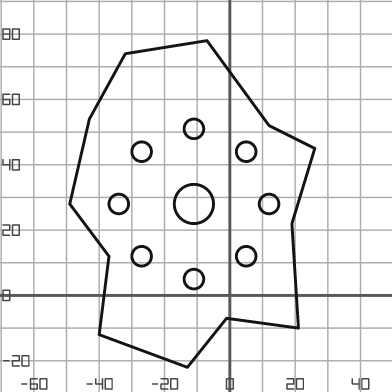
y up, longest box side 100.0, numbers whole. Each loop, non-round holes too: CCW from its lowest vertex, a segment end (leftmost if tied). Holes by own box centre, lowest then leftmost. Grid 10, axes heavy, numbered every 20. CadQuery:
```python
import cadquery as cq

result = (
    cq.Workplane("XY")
    .moveTo(-13.0, -22.0)
    .lineTo(-1.0, -7.0)
    .lineTo(21.0, -10.0)
    .lineTo(19.0, 22.0)
    .lineTo(26.0, 45.0)
    .lineTo(12.0, 52.0)
    .lineTo(-7.0, 78.0)
    .lineTo(-32.0, 74.0)
    .lineTo(-43.0, 54.0)
    .lineTo(-49.0, 28.0)
    .lineTo(-37.0, 12.0)
    .lineTo(-40.0, -12.0)
    .close()
    .moveTo(-11.0, 5.0)
    .circle(3.0)
    .moveTo(-27.0, 12.0)
    .circle(3.0)
    .moveTo(5.0, 12.0)
    .circle(3.0)
    .moveTo(-34.0, 28.0)
    .circle(3.0)
    .moveTo(-11.0, 28.0)
    .circle(6.0)
    .moveTo(12.0, 28.0)
    .circle(3.0)
    .moveTo(-27.0, 44.0)
    .circle(3.0)
    .moveTo(5.0, 44.0)
    .circle(3.0)
    .moveTo(-11.0, 51.0)
    .circle(3.0)
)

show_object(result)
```